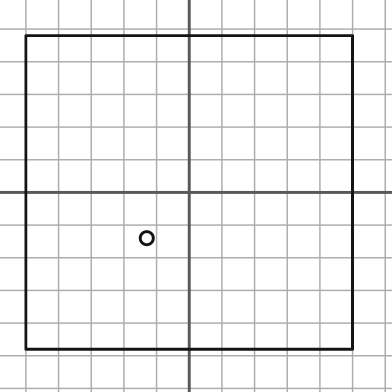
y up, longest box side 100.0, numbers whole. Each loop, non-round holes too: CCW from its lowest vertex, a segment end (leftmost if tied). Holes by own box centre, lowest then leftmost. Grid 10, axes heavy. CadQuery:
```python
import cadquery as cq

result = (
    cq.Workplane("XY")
    .moveTo(-50.0, -48.0)
    .lineTo(50.0, -48.0)
    .lineTo(50.0, 48.0)
    .lineTo(-50.0, 48.0)
    .close()
    .moveTo(-13.0, -14.0)
    .circle(2.0)
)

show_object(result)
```